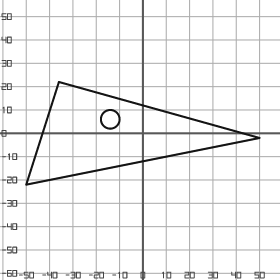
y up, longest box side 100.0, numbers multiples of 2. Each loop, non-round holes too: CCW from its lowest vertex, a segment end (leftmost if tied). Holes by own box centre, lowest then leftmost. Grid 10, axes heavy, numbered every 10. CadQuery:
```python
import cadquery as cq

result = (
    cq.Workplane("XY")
    .moveTo(-50.0, -22.0)
    .lineTo(50.0, -2.0)
    .lineTo(-36.0, 22.0)
    .close()
    .moveTo(-14.0, 6.0)
    .circle(4.0)
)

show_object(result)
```